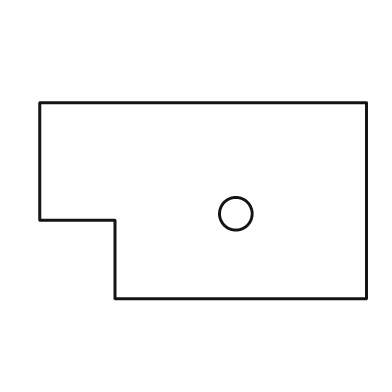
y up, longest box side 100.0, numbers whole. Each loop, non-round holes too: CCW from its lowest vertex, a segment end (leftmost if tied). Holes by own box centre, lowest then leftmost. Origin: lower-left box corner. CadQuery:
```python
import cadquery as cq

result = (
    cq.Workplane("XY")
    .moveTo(23.0, 0.0)
    .lineTo(100.0, 0.0)
    .lineTo(100.0, 60.0)
    .lineTo(0.0, 60.0)
    .lineTo(0.0, 24.0)
    .lineTo(23.0, 24.0)
    .close()
    .moveTo(60.0, 26.0)
    .circle(5.0)
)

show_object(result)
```